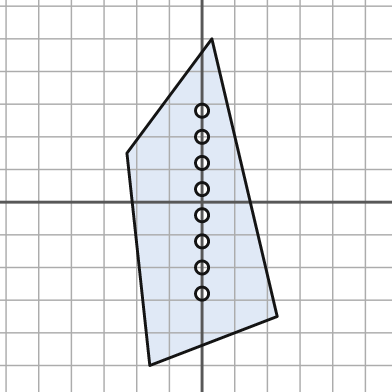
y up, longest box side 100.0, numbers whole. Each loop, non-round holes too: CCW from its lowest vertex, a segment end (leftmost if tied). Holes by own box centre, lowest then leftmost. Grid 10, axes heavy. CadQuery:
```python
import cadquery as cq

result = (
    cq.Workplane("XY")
    .moveTo(-16.0, -50.0)
    .lineTo(23.0, -35.0)
    .lineTo(3.0, 50.0)
    .lineTo(-23.0, 15.0)
    .close()
    .moveTo(0.0, -28.0)
    .circle(2.0)
    .moveTo(0.0, -20.0)
    .circle(2.0)
    .moveTo(0.0, -12.0)
    .circle(2.0)
    .moveTo(0.0, -4.0)
    .circle(2.0)
    .moveTo(0.0, 4.0)
    .circle(2.0)
    .moveTo(0.0, 12.0)
    .circle(2.0)
    .moveTo(0.0, 20.0)
    .circle(2.0)
    .moveTo(0.0, 28.0)
    .circle(2.0)
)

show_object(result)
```